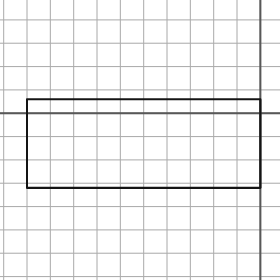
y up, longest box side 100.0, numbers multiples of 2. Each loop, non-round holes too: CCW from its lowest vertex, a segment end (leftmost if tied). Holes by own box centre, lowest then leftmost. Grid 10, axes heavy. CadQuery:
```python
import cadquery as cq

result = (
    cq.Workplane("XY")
    .moveTo(-100.0, -32.0)
    .lineTo(0.0, -32.0)
    .lineTo(0.0, 6.0)
    .lineTo(-100.0, 6.0)
    .close()
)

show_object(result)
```